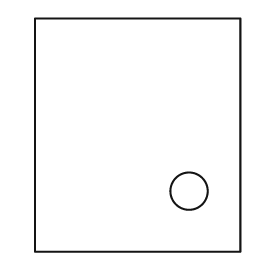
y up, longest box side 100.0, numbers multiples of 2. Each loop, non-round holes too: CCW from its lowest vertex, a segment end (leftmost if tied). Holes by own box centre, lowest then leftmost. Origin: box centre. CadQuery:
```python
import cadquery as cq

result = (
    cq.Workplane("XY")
    .moveTo(-44.0, -50.0)
    .lineTo(44.0, -50.0)
    .lineTo(44.0, 50.0)
    .lineTo(-44.0, 50.0)
    .close()
    .moveTo(22.0, -24.0)
    .circle(8.0)
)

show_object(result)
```